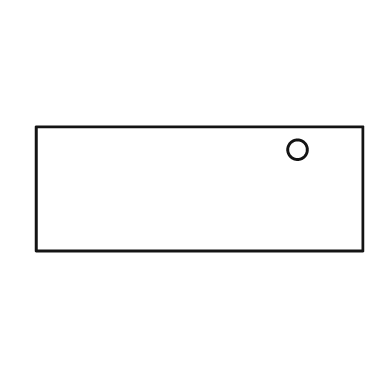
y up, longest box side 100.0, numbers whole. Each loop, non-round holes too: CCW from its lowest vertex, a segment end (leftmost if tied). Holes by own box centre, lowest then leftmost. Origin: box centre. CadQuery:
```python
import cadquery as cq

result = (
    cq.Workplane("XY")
    .moveTo(-50.0, -19.0)
    .lineTo(50.0, -19.0)
    .lineTo(50.0, 19.0)
    .lineTo(-50.0, 19.0)
    .close()
    .moveTo(30.0, 12.0)
    .circle(3.0)
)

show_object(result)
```